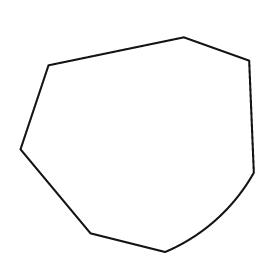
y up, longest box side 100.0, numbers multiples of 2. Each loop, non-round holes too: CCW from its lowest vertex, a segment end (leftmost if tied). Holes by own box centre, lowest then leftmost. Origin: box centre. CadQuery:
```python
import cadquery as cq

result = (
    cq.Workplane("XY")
    .moveTo(12.0, -46.0)
    .threePointArc((34.0, -32.0), (50.0, -12.0))
    .lineTo(48.0, 36.0)
    .lineTo(20.0, 46.0)
    .lineTo(-38.0, 34.0)
    .lineTo(-50.0, -2.0)
    .lineTo(-20.0, -38.0)
    .close()
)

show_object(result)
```